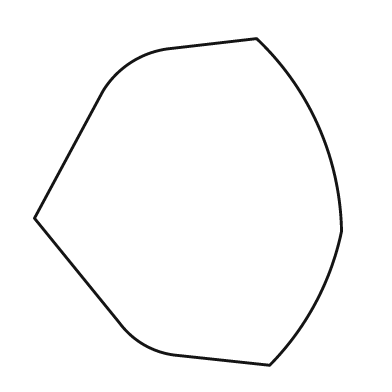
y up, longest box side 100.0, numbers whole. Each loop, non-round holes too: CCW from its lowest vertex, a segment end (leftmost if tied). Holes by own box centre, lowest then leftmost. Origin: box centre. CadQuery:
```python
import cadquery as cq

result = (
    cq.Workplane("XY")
    .moveTo(25.0, -50.0)
    .threePointArc((39.0, -31.0), (47.0, -9.0))
    .threePointArc((40.0, 23.0), (21.0, 50.0))
    .lineTo(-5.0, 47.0)
    .threePointArc((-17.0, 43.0), (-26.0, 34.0))
    .lineTo(-47.0, -5.0)
    .lineTo(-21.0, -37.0)
    .threePointArc((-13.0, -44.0), (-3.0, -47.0))
    .close()
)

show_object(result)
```